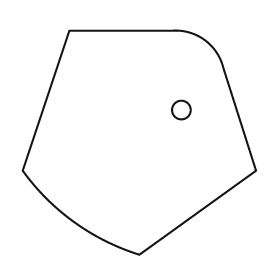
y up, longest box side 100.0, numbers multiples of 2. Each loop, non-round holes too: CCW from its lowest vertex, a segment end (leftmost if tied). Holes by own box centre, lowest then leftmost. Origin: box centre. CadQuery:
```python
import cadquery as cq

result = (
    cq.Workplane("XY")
    .moveTo(0.0, -48.0)
    .lineTo(50.0, -12.0)
    .lineTo(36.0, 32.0)
    .threePointArc((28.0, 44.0), (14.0, 48.0))
    .lineTo(-30.0, 48.0)
    .lineTo(-50.0, -12.0)
    .threePointArc((-28.0, -34.0), (0.0, -48.0))
    .close()
    .moveTo(18.0, 14.0)
    .circle(4.0)
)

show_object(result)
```